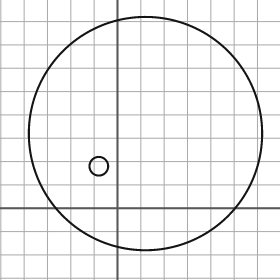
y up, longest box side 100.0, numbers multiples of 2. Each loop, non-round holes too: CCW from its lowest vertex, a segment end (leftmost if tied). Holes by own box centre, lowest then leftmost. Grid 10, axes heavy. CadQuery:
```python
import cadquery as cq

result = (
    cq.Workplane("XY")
    .moveTo(12.0, 32.0)
    .circle(50.0)
    .moveTo(-8.0, 18.0)
    .circle(4.0)
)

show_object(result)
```